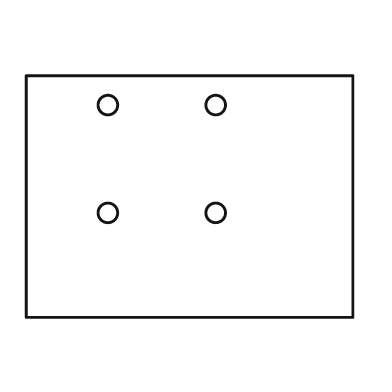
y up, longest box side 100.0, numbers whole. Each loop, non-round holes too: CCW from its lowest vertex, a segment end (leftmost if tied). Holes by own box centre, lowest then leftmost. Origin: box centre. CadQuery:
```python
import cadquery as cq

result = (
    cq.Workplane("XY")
    .moveTo(-50.0, -37.0)
    .lineTo(50.0, -37.0)
    .lineTo(50.0, 37.0)
    .lineTo(-50.0, 37.0)
    .close()
    .moveTo(-25.0, -5.0)
    .circle(3.0)
    .moveTo(8.0, -5.0)
    .circle(3.0)
    .moveTo(-25.0, 28.0)
    .circle(3.0)
    .moveTo(8.0, 28.0)
    .circle(3.0)
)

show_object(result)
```